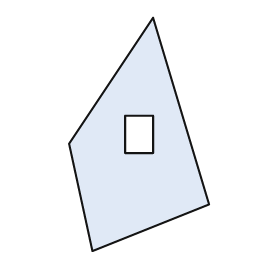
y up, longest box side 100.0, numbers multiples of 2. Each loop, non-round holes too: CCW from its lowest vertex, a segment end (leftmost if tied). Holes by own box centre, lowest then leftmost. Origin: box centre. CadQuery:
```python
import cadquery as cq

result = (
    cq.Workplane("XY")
    .moveTo(-20.0, -50.0)
    .lineTo(30.0, -30.0)
    .lineTo(6.0, 50.0)
    .lineTo(-30.0, -4.0)
    .close()
    .moveTo(-6.0, -8.0)
    .lineTo(6.0, -8.0)
    .lineTo(6.0, 8.0)
    .lineTo(-6.0, 8.0)
    .close()
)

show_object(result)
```